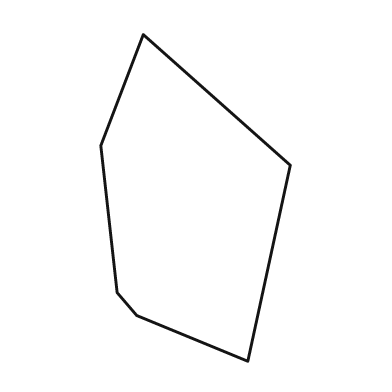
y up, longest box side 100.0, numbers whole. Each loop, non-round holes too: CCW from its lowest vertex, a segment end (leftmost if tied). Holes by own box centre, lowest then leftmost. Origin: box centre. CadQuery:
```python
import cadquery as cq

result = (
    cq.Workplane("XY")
    .moveTo(16.0, -50.0)
    .lineTo(29.0, 10.0)
    .lineTo(-16.0, 50.0)
    .lineTo(-29.0, 16.0)
    .lineTo(-24.0, -29.0)
    .lineTo(-18.0, -36.0)
    .close()
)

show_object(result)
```